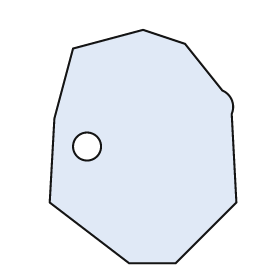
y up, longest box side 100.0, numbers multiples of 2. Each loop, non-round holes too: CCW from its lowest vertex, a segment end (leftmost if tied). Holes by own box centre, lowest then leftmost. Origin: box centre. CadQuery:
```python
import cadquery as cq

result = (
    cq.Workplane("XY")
    .moveTo(-6.0, -50.0)
    .lineTo(14.0, -50.0)
    .lineTo(40.0, -24.0)
    .lineTo(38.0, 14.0)
    .threePointArc((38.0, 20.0), (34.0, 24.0))
    .lineTo(18.0, 44.0)
    .lineTo(0.0, 50.0)
    .lineTo(-30.0, 42.0)
    .lineTo(-38.0, 12.0)
    .lineTo(-40.0, -24.0)
    .close()
    .moveTo(-24.0, 0.0)
    .circle(6.0)
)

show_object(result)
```